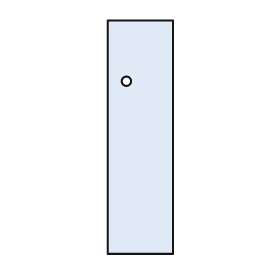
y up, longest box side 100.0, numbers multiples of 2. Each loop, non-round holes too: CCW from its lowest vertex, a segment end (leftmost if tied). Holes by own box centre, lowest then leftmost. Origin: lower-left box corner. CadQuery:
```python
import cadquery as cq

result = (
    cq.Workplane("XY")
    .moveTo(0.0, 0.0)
    .lineTo(28.0, 0.0)
    .lineTo(28.0, 100.0)
    .lineTo(0.0, 100.0)
    .close()
    .moveTo(8.0, 74.0)
    .circle(2.0)
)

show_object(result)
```